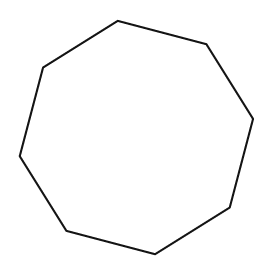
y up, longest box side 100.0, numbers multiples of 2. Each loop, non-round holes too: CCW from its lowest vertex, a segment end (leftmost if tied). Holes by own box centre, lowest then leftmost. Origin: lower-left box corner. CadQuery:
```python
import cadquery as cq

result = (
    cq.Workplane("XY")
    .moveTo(58.0, 0.0)
    .lineTo(90.0, 20.0)
    .lineTo(100.0, 58.0)
    .lineTo(80.0, 90.0)
    .lineTo(42.0, 100.0)
    .lineTo(10.0, 80.0)
    .lineTo(0.0, 42.0)
    .lineTo(20.0, 10.0)
    .close()
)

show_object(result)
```